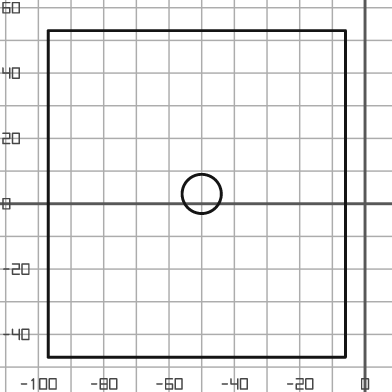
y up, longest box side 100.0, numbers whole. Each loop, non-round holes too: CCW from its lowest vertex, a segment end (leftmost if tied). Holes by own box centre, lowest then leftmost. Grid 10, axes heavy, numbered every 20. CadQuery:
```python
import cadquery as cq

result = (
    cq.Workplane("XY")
    .moveTo(-97.0, -47.0)
    .lineTo(-6.0, -47.0)
    .lineTo(-6.0, 53.0)
    .lineTo(-97.0, 53.0)
    .close()
    .moveTo(-50.0, 3.0)
    .circle(6.0)
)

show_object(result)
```